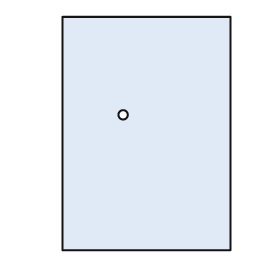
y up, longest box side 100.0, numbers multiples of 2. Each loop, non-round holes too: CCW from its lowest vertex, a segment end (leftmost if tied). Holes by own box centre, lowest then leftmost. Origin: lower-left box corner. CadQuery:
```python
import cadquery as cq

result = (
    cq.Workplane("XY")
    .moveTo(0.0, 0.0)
    .lineTo(72.0, 0.0)
    .lineTo(72.0, 100.0)
    .lineTo(0.0, 100.0)
    .close()
    .moveTo(26.0, 58.0)
    .circle(2.0)
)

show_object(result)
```